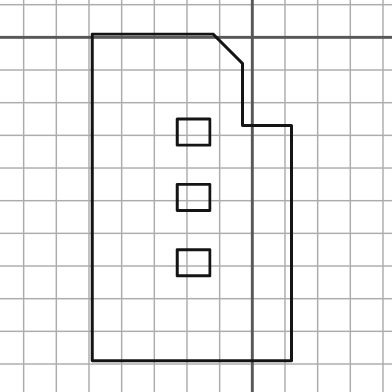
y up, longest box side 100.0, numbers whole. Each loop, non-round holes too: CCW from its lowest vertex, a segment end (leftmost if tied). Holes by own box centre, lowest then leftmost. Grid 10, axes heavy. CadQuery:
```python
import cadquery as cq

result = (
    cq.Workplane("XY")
    .moveTo(-49.0, -99.0)
    .lineTo(12.0, -99.0)
    .lineTo(12.0, -27.0)
    .lineTo(-3.0, -27.0)
    .lineTo(-3.0, -8.0)
    .lineTo(-12.0, 1.0)
    .lineTo(-49.0, 1.0)
    .close()
    .moveTo(-23.0, -73.0)
    .lineTo(-13.0, -73.0)
    .lineTo(-13.0, -65.0)
    .lineTo(-23.0, -65.0)
    .close()
    .moveTo(-23.0, -53.0)
    .lineTo(-13.0, -53.0)
    .lineTo(-13.0, -45.0)
    .lineTo(-23.0, -45.0)
    .close()
    .moveTo(-23.0, -33.0)
    .lineTo(-13.0, -33.0)
    .lineTo(-13.0, -25.0)
    .lineTo(-23.0, -25.0)
    .close()
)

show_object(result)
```